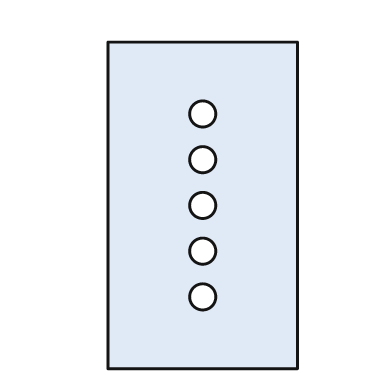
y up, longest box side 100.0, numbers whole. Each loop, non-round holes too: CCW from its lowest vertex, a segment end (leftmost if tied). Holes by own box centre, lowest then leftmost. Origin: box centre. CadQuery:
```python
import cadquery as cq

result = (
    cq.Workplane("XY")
    .moveTo(-29.0, -50.0)
    .lineTo(29.0, -50.0)
    .lineTo(29.0, 50.0)
    .lineTo(-29.0, 50.0)
    .close()
    .moveTo(0.0, -28.0)
    .circle(4.0)
    .moveTo(0.0, -14.0)
    .circle(4.0)
    .moveTo(0.0, 0.0)
    .circle(4.0)
    .moveTo(0.0, 14.0)
    .circle(4.0)
    .moveTo(0.0, 28.0)
    .circle(4.0)
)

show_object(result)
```